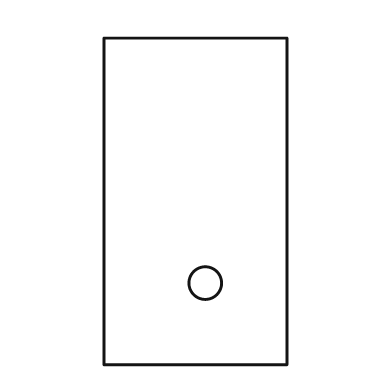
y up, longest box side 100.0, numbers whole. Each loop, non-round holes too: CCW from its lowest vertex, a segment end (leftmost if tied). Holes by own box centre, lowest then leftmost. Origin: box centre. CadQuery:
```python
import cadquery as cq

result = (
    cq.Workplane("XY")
    .moveTo(-28.0, -50.0)
    .lineTo(28.0, -50.0)
    .lineTo(28.0, 50.0)
    .lineTo(-28.0, 50.0)
    .close()
    .moveTo(3.0, -25.0)
    .circle(5.0)
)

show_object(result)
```